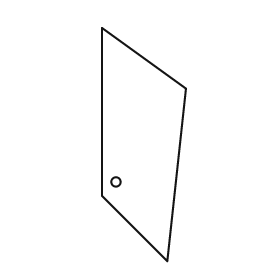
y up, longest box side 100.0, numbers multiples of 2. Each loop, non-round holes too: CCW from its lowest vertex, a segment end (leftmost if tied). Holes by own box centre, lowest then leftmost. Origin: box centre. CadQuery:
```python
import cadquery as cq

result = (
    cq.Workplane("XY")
    .moveTo(10.0, -50.0)
    .lineTo(18.0, 24.0)
    .lineTo(-18.0, 50.0)
    .lineTo(-18.0, -22.0)
    .close()
    .moveTo(-12.0, -16.0)
    .circle(2.0)
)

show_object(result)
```